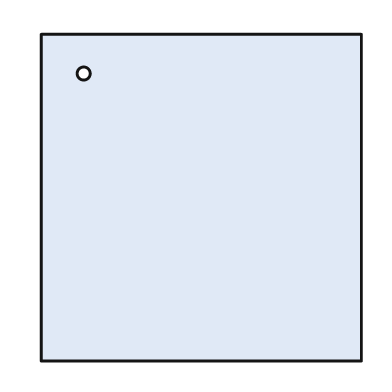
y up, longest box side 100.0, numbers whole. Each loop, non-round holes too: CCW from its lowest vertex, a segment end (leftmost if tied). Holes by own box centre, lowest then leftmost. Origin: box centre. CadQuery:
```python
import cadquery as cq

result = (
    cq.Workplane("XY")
    .moveTo(-49.0, -50.0)
    .lineTo(49.0, -50.0)
    .lineTo(49.0, 50.0)
    .lineTo(-49.0, 50.0)
    .close()
    .moveTo(-36.0, 38.0)
    .circle(2.0)
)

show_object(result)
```